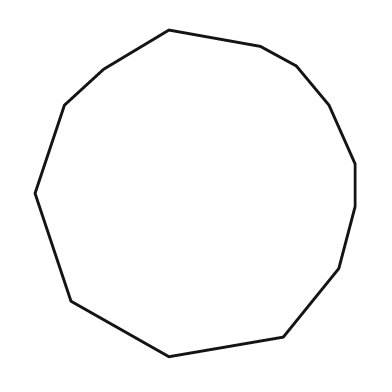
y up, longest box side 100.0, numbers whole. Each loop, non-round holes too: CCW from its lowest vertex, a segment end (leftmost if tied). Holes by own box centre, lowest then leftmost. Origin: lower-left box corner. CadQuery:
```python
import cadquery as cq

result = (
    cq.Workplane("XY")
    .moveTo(41.0, 0.0)
    .lineTo(76.0, 6.0)
    .lineTo(93.0, 27.0)
    .lineTo(98.0, 46.0)
    .lineTo(98.0, 59.0)
    .lineTo(90.0, 77.0)
    .lineTo(80.0, 89.0)
    .lineTo(69.0, 95.0)
    .lineTo(41.0, 100.0)
    .lineTo(21.0, 88.0)
    .lineTo(9.0, 77.0)
    .lineTo(0.0, 50.0)
    .lineTo(11.0, 17.0)
    .close()
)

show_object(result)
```